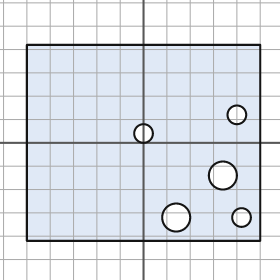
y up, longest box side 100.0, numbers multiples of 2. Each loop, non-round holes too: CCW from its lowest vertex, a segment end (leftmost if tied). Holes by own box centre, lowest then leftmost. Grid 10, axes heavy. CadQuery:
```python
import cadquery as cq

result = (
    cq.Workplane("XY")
    .moveTo(-50.0, -42.0)
    .lineTo(50.0, -42.0)
    .lineTo(50.0, 42.0)
    .lineTo(-50.0, 42.0)
    .close()
    .moveTo(14.0, -32.0)
    .circle(6.0)
    .moveTo(42.0, -32.0)
    .circle(4.0)
    .moveTo(34.0, -14.0)
    .circle(6.0)
    .moveTo(0.0, 4.0)
    .circle(4.0)
    .moveTo(40.0, 12.0)
    .circle(4.0)
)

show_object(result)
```